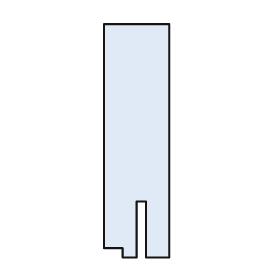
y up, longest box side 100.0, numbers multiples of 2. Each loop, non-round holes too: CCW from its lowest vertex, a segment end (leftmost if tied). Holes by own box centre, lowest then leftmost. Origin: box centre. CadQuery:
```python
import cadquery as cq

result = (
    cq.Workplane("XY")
    .moveTo(-6.0, -50.0)
    .lineTo(0.0, -50.0)
    .lineTo(0.0, -26.0)
    .lineTo(4.0, -26.0)
    .lineTo(4.0, -50.0)
    .lineTo(14.0, -50.0)
    .lineTo(14.0, 50.0)
    .lineTo(-14.0, 50.0)
    .lineTo(-14.0, -46.0)
    .lineTo(-6.0, -46.0)
    .close()
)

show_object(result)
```